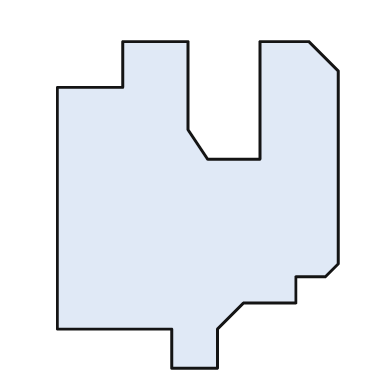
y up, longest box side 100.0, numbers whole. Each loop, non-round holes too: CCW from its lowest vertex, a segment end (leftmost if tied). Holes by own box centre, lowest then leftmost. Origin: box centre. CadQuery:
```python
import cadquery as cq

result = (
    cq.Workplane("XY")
    .moveTo(-8.0, -50.0)
    .lineTo(6.0, -50.0)
    .lineTo(6.0, -38.0)
    .lineTo(14.0, -30.0)
    .lineTo(30.0, -30.0)
    .lineTo(30.0, -22.0)
    .lineTo(39.0, -22.0)
    .lineTo(43.0, -18.0)
    .lineTo(43.0, 41.0)
    .lineTo(34.0, 50.0)
    .lineTo(19.0, 50.0)
    .lineTo(19.0, 14.0)
    .lineTo(3.0, 14.0)
    .lineTo(-3.0, 23.0)
    .lineTo(-3.0, 50.0)
    .lineTo(-23.0, 50.0)
    .lineTo(-23.0, 36.0)
    .lineTo(-43.0, 36.0)
    .lineTo(-43.0, -38.0)
    .lineTo(-8.0, -38.0)
    .close()
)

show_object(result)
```